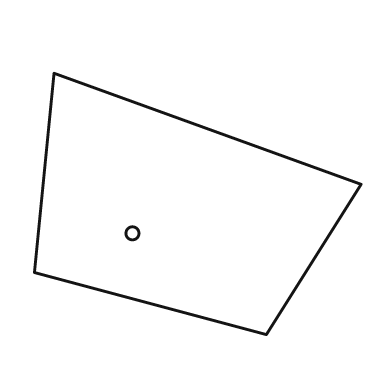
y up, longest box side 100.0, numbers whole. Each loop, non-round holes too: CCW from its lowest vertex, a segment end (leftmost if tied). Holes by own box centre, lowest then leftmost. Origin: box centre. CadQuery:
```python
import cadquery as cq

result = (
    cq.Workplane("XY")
    .moveTo(21.0, -40.0)
    .lineTo(50.0, 6.0)
    .lineTo(-44.0, 40.0)
    .lineTo(-50.0, -21.0)
    .close()
    .moveTo(-20.0, -9.0)
    .circle(2.0)
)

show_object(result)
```